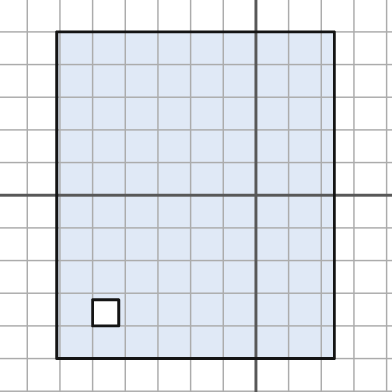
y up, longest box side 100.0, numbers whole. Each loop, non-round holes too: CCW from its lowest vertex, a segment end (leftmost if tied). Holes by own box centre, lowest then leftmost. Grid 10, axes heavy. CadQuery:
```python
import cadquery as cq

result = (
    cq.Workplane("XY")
    .moveTo(-61.0, -50.0)
    .lineTo(24.0, -50.0)
    .lineTo(24.0, 50.0)
    .lineTo(-61.0, 50.0)
    .close()
    .moveTo(-50.0, -40.0)
    .lineTo(-42.0, -40.0)
    .lineTo(-42.0, -32.0)
    .lineTo(-50.0, -32.0)
    .close()
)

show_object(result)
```